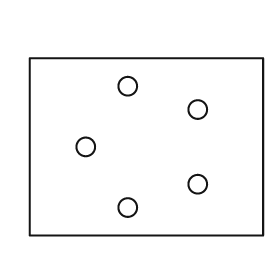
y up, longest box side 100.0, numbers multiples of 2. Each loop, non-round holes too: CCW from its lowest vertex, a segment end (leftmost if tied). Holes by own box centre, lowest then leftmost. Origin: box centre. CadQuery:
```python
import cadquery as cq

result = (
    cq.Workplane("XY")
    .moveTo(-50.0, -38.0)
    .lineTo(50.0, -38.0)
    .lineTo(50.0, 38.0)
    .lineTo(-50.0, 38.0)
    .close()
    .moveTo(-8.0, -26.0)
    .circle(4.0)
    .moveTo(22.0, -16.0)
    .circle(4.0)
    .moveTo(-26.0, 0.0)
    .circle(4.0)
    .moveTo(22.0, 16.0)
    .circle(4.0)
    .moveTo(-8.0, 26.0)
    .circle(4.0)
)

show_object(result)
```